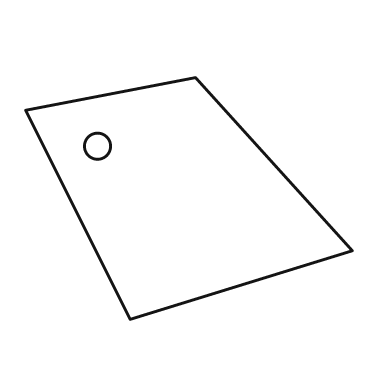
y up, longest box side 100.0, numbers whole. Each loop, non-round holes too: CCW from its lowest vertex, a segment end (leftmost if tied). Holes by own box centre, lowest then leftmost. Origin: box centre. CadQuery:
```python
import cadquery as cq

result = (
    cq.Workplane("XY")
    .moveTo(-18.0, -37.0)
    .lineTo(50.0, -16.0)
    .lineTo(2.0, 37.0)
    .lineTo(-50.0, 27.0)
    .close()
    .moveTo(-28.0, 16.0)
    .circle(4.0)
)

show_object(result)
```